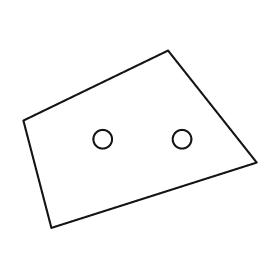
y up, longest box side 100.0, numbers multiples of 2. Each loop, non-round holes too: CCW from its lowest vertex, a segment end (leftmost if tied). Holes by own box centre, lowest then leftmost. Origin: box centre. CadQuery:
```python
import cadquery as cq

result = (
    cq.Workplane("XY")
    .moveTo(-38.0, -38.0)
    .lineTo(50.0, -10.0)
    .lineTo(12.0, 38.0)
    .lineTo(-50.0, 8.0)
    .close()
    .moveTo(-16.0, 0.0)
    .circle(4.0)
    .moveTo(18.0, 0.0)
    .circle(4.0)
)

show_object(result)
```